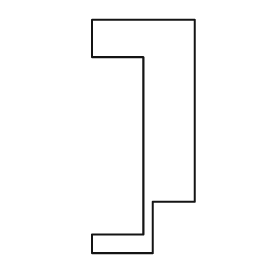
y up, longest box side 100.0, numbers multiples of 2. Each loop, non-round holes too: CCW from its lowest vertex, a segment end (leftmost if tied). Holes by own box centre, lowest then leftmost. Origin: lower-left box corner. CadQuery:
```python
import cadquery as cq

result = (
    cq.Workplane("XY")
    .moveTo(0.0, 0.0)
    .lineTo(26.0, 0.0)
    .lineTo(26.0, 22.0)
    .lineTo(44.0, 22.0)
    .lineTo(44.0, 100.0)
    .lineTo(0.0, 100.0)
    .lineTo(0.0, 84.0)
    .lineTo(22.0, 84.0)
    .lineTo(22.0, 8.0)
    .lineTo(0.0, 8.0)
    .close()
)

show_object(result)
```